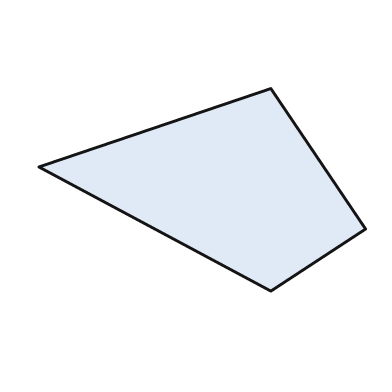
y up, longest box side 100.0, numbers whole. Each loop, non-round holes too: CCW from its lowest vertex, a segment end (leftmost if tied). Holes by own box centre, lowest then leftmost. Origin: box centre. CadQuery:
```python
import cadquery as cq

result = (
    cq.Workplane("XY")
    .moveTo(21.0, -31.0)
    .lineTo(50.0, -12.0)
    .lineTo(21.0, 31.0)
    .lineTo(-50.0, 7.0)
    .close()
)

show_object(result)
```